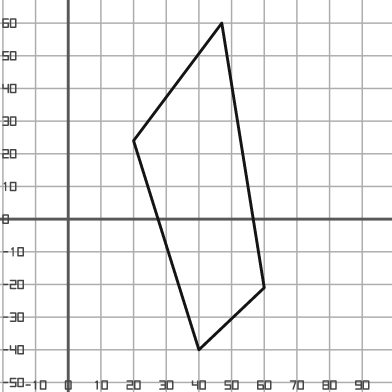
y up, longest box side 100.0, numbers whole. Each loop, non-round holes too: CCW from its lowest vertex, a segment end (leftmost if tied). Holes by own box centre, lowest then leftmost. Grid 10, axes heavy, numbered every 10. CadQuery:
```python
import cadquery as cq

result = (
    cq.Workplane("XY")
    .moveTo(40.0, -40.0)
    .lineTo(60.0, -21.0)
    .lineTo(47.0, 60.0)
    .lineTo(20.0, 24.0)
    .close()
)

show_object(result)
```